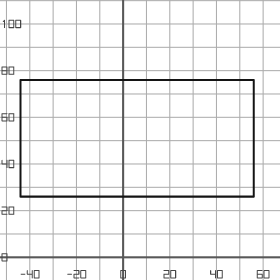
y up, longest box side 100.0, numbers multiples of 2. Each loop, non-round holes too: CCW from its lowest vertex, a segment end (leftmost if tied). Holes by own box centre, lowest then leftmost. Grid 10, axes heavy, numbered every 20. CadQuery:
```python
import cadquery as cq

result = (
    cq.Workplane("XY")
    .moveTo(-44.0, 26.0)
    .lineTo(56.0, 26.0)
    .lineTo(56.0, 76.0)
    .lineTo(-44.0, 76.0)
    .close()
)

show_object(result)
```